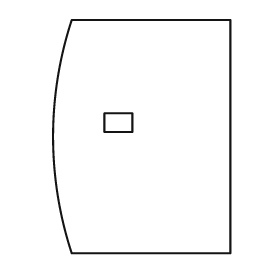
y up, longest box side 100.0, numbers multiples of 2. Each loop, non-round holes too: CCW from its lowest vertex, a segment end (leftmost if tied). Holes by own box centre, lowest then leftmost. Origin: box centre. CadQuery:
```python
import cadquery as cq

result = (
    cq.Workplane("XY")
    .moveTo(-30.0, -50.0)
    .lineTo(38.0, -50.0)
    .lineTo(38.0, 50.0)
    .lineTo(-30.0, 50.0)
    .threePointArc((-38.0, 0.0), (-30.0, -50.0))
    .close()
    .moveTo(-16.0, 2.0)
    .lineTo(-4.0, 2.0)
    .lineTo(-4.0, 10.0)
    .lineTo(-16.0, 10.0)
    .close()
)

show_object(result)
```